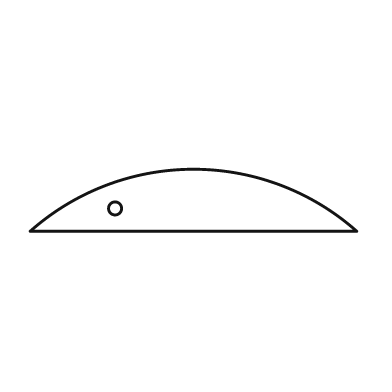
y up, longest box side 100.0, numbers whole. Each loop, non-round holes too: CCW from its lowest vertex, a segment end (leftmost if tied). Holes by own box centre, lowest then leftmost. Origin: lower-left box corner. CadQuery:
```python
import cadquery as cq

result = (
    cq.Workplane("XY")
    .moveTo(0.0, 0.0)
    .lineTo(100.0, 0.0)
    .threePointArc((50.0, 19.0), (0.0, 0.0))
    .close()
    .moveTo(26.0, 7.0)
    .circle(2.0)
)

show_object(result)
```